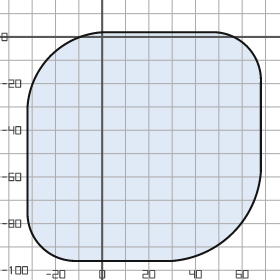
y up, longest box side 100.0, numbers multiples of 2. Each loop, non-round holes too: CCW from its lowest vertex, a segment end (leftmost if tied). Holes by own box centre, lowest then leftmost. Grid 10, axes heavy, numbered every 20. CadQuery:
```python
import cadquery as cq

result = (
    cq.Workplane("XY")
    .moveTo(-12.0, -96.0)
    .lineTo(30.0, -96.0)
    .threePointArc((56.0, -84.0), (68.0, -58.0))
    .lineTo(68.0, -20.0)
    .threePointArc((62.0, -4.0), (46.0, 2.0))
    .lineTo(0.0, 2.0)
    .threePointArc((-22.0, -8.0), (-32.0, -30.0))
    .lineTo(-32.0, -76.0)
    .threePointArc((-26.0, -90.0), (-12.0, -96.0))
    .close()
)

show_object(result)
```